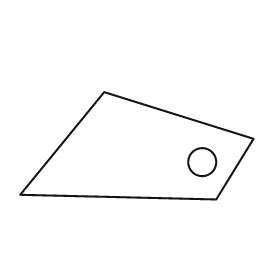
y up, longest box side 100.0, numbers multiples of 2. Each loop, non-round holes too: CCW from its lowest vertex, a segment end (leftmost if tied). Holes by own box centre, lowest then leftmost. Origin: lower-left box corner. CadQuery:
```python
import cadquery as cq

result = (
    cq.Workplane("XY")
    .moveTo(84.0, 0.0)
    .lineTo(100.0, 26.0)
    .lineTo(36.0, 46.0)
    .lineTo(0.0, 2.0)
    .close()
    .moveTo(78.0, 16.0)
    .circle(6.0)
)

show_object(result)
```